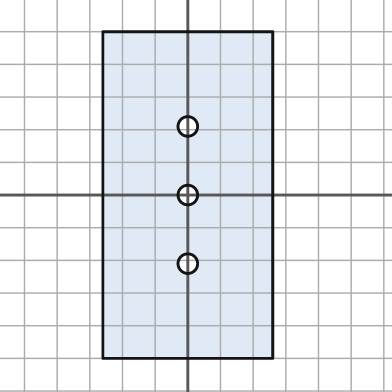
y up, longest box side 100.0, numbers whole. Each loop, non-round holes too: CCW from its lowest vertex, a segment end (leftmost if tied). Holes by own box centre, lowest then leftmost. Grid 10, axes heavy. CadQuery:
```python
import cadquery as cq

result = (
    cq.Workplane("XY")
    .moveTo(-26.0, -50.0)
    .lineTo(26.0, -50.0)
    .lineTo(26.0, 50.0)
    .lineTo(-26.0, 50.0)
    .close()
    .moveTo(0.0, -21.0)
    .circle(3.0)
    .moveTo(0.0, 0.0)
    .circle(3.0)
    .moveTo(0.0, 21.0)
    .circle(3.0)
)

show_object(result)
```